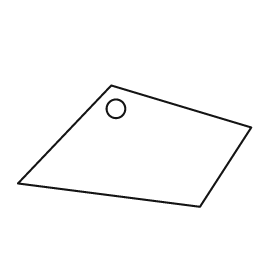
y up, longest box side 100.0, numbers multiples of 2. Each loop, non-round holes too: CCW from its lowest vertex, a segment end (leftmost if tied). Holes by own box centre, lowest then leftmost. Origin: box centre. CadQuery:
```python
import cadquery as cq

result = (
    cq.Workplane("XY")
    .moveTo(28.0, -26.0)
    .lineTo(50.0, 8.0)
    .lineTo(-10.0, 26.0)
    .lineTo(-50.0, -16.0)
    .close()
    .moveTo(-8.0, 16.0)
    .circle(4.0)
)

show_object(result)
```